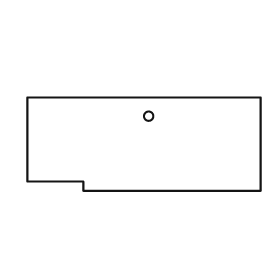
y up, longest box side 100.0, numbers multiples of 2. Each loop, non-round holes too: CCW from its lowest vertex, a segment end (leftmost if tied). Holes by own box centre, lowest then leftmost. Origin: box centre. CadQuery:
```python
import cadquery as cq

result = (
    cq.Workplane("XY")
    .moveTo(-26.0, -20.0)
    .lineTo(50.0, -20.0)
    .lineTo(50.0, 20.0)
    .lineTo(-50.0, 20.0)
    .lineTo(-50.0, -16.0)
    .lineTo(-26.0, -16.0)
    .close()
    .moveTo(2.0, 12.0)
    .circle(2.0)
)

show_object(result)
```